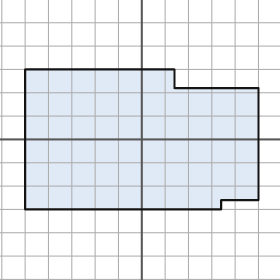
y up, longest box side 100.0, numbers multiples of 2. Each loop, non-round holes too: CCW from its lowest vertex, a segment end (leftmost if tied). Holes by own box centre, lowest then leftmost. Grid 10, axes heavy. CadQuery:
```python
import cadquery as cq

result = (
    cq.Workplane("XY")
    .moveTo(-50.0, -30.0)
    .lineTo(34.0, -30.0)
    .lineTo(34.0, -26.0)
    .lineTo(50.0, -26.0)
    .lineTo(50.0, 22.0)
    .lineTo(14.0, 22.0)
    .lineTo(14.0, 30.0)
    .lineTo(-50.0, 30.0)
    .close()
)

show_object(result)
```